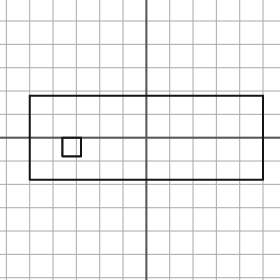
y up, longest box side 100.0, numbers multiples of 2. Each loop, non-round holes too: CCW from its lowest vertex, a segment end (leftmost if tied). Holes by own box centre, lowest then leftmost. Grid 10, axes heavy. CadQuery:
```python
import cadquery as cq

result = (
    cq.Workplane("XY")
    .moveTo(-50.0, -18.0)
    .lineTo(50.0, -18.0)
    .lineTo(50.0, 18.0)
    .lineTo(-50.0, 18.0)
    .close()
    .moveTo(-36.0, -8.0)
    .lineTo(-28.0, -8.0)
    .lineTo(-28.0, 0.0)
    .lineTo(-36.0, 0.0)
    .close()
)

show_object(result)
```